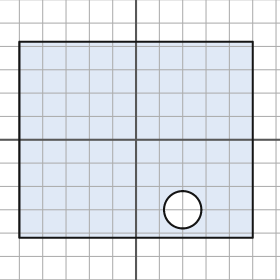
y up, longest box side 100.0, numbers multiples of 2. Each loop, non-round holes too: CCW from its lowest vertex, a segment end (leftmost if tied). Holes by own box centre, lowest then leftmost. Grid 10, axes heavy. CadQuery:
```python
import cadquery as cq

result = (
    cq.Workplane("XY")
    .moveTo(-50.0, -42.0)
    .lineTo(50.0, -42.0)
    .lineTo(50.0, 42.0)
    .lineTo(-50.0, 42.0)
    .close()
    .moveTo(20.0, -30.0)
    .circle(8.0)
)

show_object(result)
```